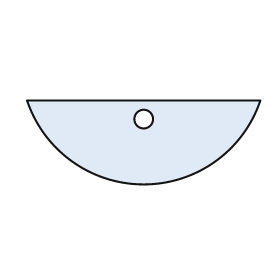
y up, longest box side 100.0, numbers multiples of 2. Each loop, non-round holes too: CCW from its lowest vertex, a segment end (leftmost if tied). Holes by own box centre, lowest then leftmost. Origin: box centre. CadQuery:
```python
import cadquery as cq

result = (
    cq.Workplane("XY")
    .moveTo(-50.0, 18.0)
    .threePointArc((0.0, -18.0), (50.0, 18.0))
    .close()
    .moveTo(0.0, 10.0)
    .circle(4.0)
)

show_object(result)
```